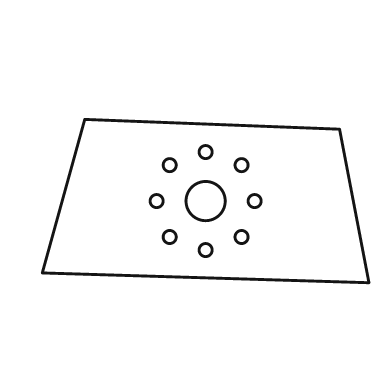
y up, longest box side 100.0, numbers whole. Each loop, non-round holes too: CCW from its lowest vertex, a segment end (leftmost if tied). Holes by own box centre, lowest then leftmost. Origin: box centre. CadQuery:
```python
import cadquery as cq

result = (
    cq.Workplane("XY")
    .moveTo(50.0, -25.0)
    .lineTo(41.0, 22.0)
    .lineTo(-37.0, 25.0)
    .lineTo(-50.0, -22.0)
    .close()
    .moveTo(0.0, -15.0)
    .circle(2.0)
    .moveTo(-11.0, -11.0)
    .circle(2.0)
    .moveTo(11.0, -11.0)
    .circle(2.0)
    .moveTo(-15.0, 0.0)
    .circle(2.0)
    .moveTo(0.0, 0.0)
    .circle(6.0)
    .moveTo(15.0, 0.0)
    .circle(2.0)
    .moveTo(-11.0, 11.0)
    .circle(2.0)
    .moveTo(11.0, 11.0)
    .circle(2.0)
    .moveTo(0.0, 15.0)
    .circle(2.0)
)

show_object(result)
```